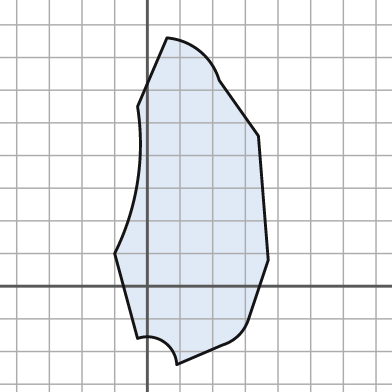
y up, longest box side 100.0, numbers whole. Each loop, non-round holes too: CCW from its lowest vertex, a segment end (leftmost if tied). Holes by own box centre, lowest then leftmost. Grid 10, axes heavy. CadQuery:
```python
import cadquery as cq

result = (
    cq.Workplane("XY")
    .moveTo(9.0, -24.0)
    .lineTo(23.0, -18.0)
    .threePointArc((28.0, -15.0), (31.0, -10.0))
    .lineTo(37.0, 8.0)
    .lineTo(34.0, 46.0)
    .lineTo(22.0, 63.0)
    .threePointArc((16.0, 72.0), (6.0, 76.0))
    .lineTo(-3.0, 55.0)
    .threePointArc((-3.0, 32.0), (-10.0, 10.0))
    .lineTo(-3.0, -16.0)
    .threePointArc((5.0, -17.0), (9.0, -24.0))
    .close()
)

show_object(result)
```